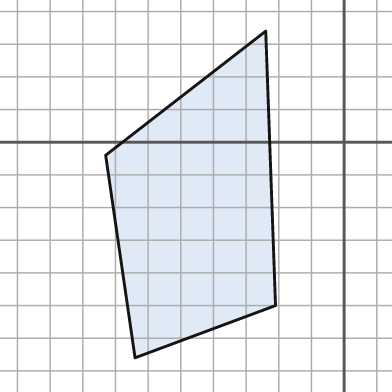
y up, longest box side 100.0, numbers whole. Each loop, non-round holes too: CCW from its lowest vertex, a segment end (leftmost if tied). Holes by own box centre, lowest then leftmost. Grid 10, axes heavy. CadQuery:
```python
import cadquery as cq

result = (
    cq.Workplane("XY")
    .moveTo(-64.0, -66.0)
    .lineTo(-21.0, -50.0)
    .lineTo(-24.0, 34.0)
    .lineTo(-73.0, -4.0)
    .close()
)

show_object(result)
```